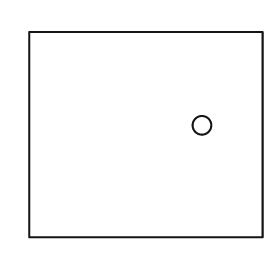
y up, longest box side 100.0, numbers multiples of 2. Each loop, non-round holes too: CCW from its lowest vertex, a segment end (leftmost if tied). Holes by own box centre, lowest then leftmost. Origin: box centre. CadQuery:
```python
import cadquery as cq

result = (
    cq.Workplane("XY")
    .moveTo(-50.0, -44.0)
    .lineTo(50.0, -44.0)
    .lineTo(50.0, 44.0)
    .lineTo(-50.0, 44.0)
    .close()
    .moveTo(24.0, 4.0)
    .circle(4.0)
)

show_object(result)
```